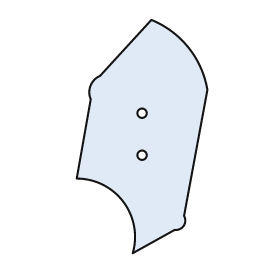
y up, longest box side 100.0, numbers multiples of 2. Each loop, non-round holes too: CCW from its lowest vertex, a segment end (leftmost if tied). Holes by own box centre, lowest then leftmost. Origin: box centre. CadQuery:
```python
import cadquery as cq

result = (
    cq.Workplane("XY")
    .moveTo(-4.0, -50.0)
    .lineTo(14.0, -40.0)
    .threePointArc((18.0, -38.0), (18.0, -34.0))
    .lineTo(28.0, 20.0)
    .threePointArc((20.0, 38.0), (4.0, 50.0))
    .lineTo(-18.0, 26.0)
    .threePointArc((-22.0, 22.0), (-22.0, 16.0))
    .lineTo(-28.0, -18.0)
    .threePointArc((-8.0, -28.0), (-4.0, -50.0))
    .close()
    .moveTo(0.0, -8.0)
    .circle(2.0)
    .moveTo(0.0, 10.0)
    .circle(2.0)
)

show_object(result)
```